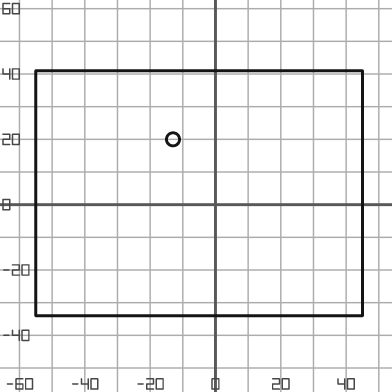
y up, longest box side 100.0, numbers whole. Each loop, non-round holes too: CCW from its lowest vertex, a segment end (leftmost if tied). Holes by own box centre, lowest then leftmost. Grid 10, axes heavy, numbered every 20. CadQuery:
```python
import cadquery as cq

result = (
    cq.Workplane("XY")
    .moveTo(-55.0, -34.0)
    .lineTo(45.0, -34.0)
    .lineTo(45.0, 41.0)
    .lineTo(-55.0, 41.0)
    .close()
    .moveTo(-13.0, 20.0)
    .circle(2.0)
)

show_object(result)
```